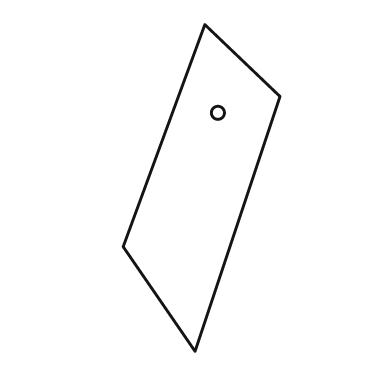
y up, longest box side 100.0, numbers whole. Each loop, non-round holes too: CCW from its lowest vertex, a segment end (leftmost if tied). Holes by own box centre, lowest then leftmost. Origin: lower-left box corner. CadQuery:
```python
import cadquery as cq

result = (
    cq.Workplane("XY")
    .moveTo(22.0, 0.0)
    .lineTo(48.0, 78.0)
    .lineTo(25.0, 100.0)
    .lineTo(0.0, 32.0)
    .close()
    .moveTo(29.0, 73.0)
    .circle(2.0)
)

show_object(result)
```